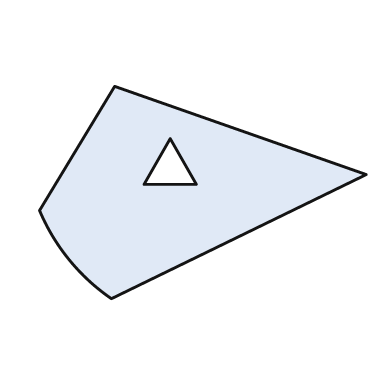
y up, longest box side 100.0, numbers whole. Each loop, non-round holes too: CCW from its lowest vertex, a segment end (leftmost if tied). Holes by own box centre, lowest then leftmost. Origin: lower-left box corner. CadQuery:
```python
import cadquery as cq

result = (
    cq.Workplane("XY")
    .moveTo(22.0, 0.0)
    .lineTo(100.0, 38.0)
    .lineTo(23.0, 65.0)
    .lineTo(0.0, 27.0)
    .threePointArc((9.0, 12.0), (22.0, 0.0))
    .close()
    .moveTo(32.0, 35.0)
    .lineTo(48.0, 35.0)
    .lineTo(40.0, 49.0)
    .close()
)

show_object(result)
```